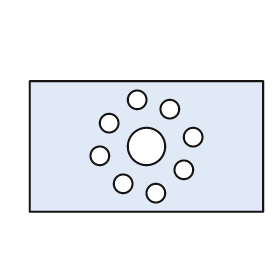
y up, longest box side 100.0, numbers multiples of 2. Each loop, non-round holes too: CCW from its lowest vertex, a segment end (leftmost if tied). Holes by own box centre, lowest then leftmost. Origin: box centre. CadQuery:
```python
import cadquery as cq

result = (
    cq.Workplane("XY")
    .moveTo(-50.0, -28.0)
    .lineTo(50.0, -28.0)
    .lineTo(50.0, 28.0)
    .lineTo(-50.0, 28.0)
    .close()
    .moveTo(4.0, -20.0)
    .circle(4.0)
    .moveTo(-10.0, -16.0)
    .circle(4.0)
    .moveTo(16.0, -10.0)
    .circle(4.0)
    .moveTo(-20.0, -4.0)
    .circle(4.0)
    .moveTo(0.0, 0.0)
    .circle(8.0)
    .moveTo(20.0, 4.0)
    .circle(4.0)
    .moveTo(-16.0, 10.0)
    .circle(4.0)
    .moveTo(10.0, 16.0)
    .circle(4.0)
    .moveTo(-4.0, 20.0)
    .circle(4.0)
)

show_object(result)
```